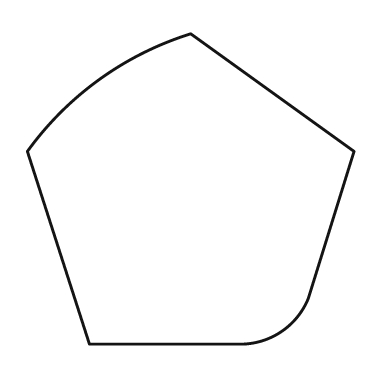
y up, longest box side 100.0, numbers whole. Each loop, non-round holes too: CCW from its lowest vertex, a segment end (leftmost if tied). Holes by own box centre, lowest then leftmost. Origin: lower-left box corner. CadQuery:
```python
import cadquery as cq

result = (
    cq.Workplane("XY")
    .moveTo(19.0, 0.0)
    .lineTo(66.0, 0.0)
    .threePointArc((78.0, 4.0), (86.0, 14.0))
    .lineTo(100.0, 59.0)
    .lineTo(50.0, 95.0)
    .threePointArc((22.0, 81.0), (0.0, 59.0))
    .close()
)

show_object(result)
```